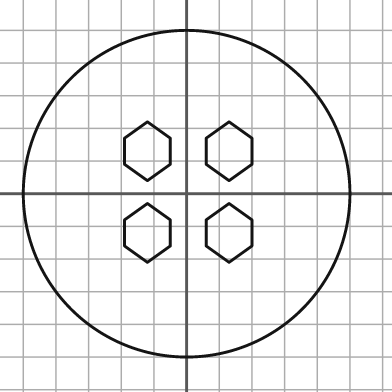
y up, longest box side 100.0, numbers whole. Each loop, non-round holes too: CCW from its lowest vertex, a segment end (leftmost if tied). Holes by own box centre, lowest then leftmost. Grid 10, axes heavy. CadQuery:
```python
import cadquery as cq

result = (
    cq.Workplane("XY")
    .moveTo(0.0, 0.0)
    .circle(50.0)
    .moveTo(-12.0, -21.0)
    .lineTo(-5.0, -16.0)
    .lineTo(-5.0, -8.0)
    .lineTo(-12.0, -3.0)
    .lineTo(-19.0, -8.0)
    .lineTo(-19.0, -16.0)
    .close()
    .moveTo(13.0, -21.0)
    .lineTo(20.0, -16.0)
    .lineTo(20.0, -8.0)
    .lineTo(13.0, -3.0)
    .lineTo(6.0, -8.0)
    .lineTo(6.0, -16.0)
    .close()
    .moveTo(-12.0, 4.0)
    .lineTo(-5.0, 9.0)
    .lineTo(-5.0, 17.0)
    .lineTo(-12.0, 22.0)
    .lineTo(-19.0, 17.0)
    .lineTo(-19.0, 9.0)
    .close()
    .moveTo(13.0, 4.0)
    .lineTo(20.0, 9.0)
    .lineTo(20.0, 17.0)
    .lineTo(13.0, 22.0)
    .lineTo(6.0, 17.0)
    .lineTo(6.0, 9.0)
    .close()
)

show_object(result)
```